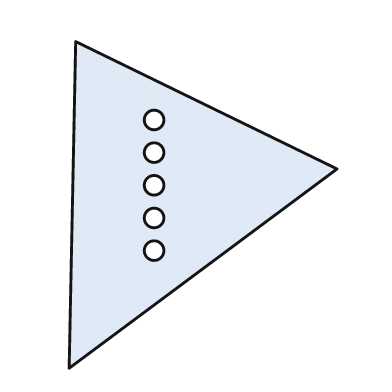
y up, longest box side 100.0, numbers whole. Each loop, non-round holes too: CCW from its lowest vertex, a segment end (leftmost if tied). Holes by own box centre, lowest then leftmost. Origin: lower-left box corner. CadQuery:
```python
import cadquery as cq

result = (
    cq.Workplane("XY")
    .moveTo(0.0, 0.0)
    .lineTo(82.0, 61.0)
    .lineTo(2.0, 100.0)
    .close()
    .moveTo(26.0, 36.0)
    .circle(3.0)
    .moveTo(26.0, 46.0)
    .circle(3.0)
    .moveTo(26.0, 56.0)
    .circle(3.0)
    .moveTo(26.0, 66.0)
    .circle(3.0)
    .moveTo(26.0, 76.0)
    .circle(3.0)
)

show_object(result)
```